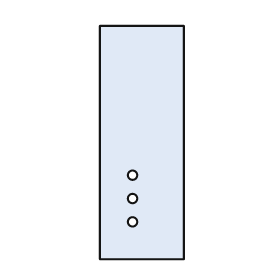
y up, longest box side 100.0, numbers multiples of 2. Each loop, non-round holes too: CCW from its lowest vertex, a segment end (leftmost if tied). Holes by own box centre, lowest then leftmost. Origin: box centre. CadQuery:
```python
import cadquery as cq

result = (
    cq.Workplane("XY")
    .moveTo(-18.0, -50.0)
    .lineTo(18.0, -50.0)
    .lineTo(18.0, 50.0)
    .lineTo(-18.0, 50.0)
    .close()
    .moveTo(-4.0, -34.0)
    .circle(2.0)
    .moveTo(-4.0, -24.0)
    .circle(2.0)
    .moveTo(-4.0, -14.0)
    .circle(2.0)
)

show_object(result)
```